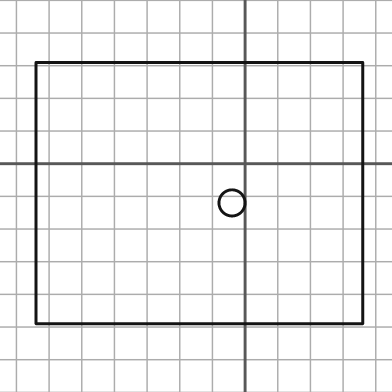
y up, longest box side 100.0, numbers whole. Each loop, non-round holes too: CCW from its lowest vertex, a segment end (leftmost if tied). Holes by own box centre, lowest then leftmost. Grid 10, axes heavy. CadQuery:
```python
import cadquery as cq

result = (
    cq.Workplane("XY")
    .moveTo(-64.0, -49.0)
    .lineTo(36.0, -49.0)
    .lineTo(36.0, 31.0)
    .lineTo(-64.0, 31.0)
    .close()
    .moveTo(-4.0, -12.0)
    .circle(4.0)
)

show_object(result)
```